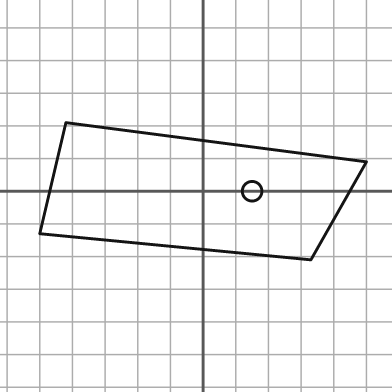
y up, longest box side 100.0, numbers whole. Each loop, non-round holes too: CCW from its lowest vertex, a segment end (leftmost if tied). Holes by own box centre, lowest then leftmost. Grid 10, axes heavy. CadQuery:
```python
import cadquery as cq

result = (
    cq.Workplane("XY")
    .moveTo(33.0, -21.0)
    .lineTo(50.0, 9.0)
    .lineTo(-42.0, 21.0)
    .lineTo(-50.0, -13.0)
    .close()
    .moveTo(15.0, 0.0)
    .circle(3.0)
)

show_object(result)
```